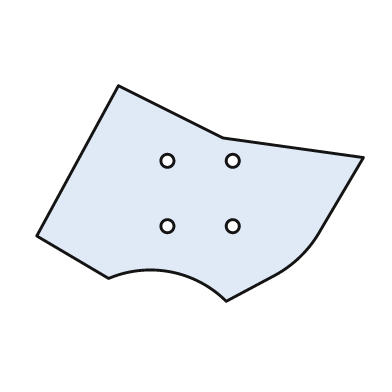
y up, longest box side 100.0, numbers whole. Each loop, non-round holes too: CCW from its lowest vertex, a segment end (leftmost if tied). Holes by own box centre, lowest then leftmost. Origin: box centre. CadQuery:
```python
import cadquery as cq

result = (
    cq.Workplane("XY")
    .moveTo(8.0, -33.0)
    .lineTo(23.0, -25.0)
    .threePointArc((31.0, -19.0), (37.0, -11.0))
    .lineTo(50.0, 11.0)
    .lineTo(7.0, 17.0)
    .lineTo(-25.0, 33.0)
    .lineTo(-50.0, -13.0)
    .lineTo(-28.0, -26.0)
    .threePointArc((-9.0, -24.0), (8.0, -33.0))
    .close()
    .moveTo(-10.0, -10.0)
    .circle(2.0)
    .moveTo(10.0, -10.0)
    .circle(2.0)
    .moveTo(-10.0, 10.0)
    .circle(2.0)
    .moveTo(10.0, 10.0)
    .circle(2.0)
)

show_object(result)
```